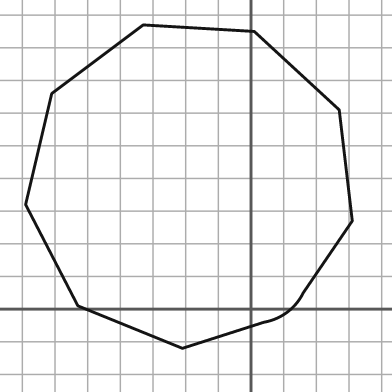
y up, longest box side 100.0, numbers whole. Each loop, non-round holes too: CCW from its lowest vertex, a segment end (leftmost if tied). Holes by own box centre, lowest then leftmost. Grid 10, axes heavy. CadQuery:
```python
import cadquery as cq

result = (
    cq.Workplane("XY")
    .moveTo(-21.0, -12.0)
    .lineTo(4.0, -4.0)
    .threePointArc((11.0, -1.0), (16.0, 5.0))
    .lineTo(31.0, 27.0)
    .lineTo(27.0, 61.0)
    .lineTo(1.0, 85.0)
    .lineTo(-33.0, 87.0)
    .lineTo(-61.0, 66.0)
    .lineTo(-69.0, 32.0)
    .lineTo(-53.0, 1.0)
    .close()
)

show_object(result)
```